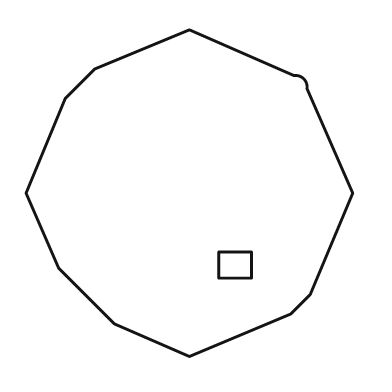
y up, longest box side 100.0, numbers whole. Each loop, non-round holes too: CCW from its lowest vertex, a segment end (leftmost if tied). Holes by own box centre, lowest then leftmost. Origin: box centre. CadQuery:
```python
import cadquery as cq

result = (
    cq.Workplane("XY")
    .moveTo(0.0, -50.0)
    .lineTo(31.0, -37.0)
    .lineTo(37.0, -31.0)
    .lineTo(50.0, 0.0)
    .lineTo(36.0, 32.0)
    .threePointArc((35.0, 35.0), (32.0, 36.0))
    .lineTo(0.0, 50.0)
    .lineTo(-29.0, 38.0)
    .lineTo(-38.0, 29.0)
    .lineTo(-50.0, 0.0)
    .lineTo(-40.0, -23.0)
    .lineTo(-23.0, -40.0)
    .close()
    .moveTo(9.0, -26.0)
    .lineTo(19.0, -26.0)
    .lineTo(19.0, -18.0)
    .lineTo(9.0, -18.0)
    .close()
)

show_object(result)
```